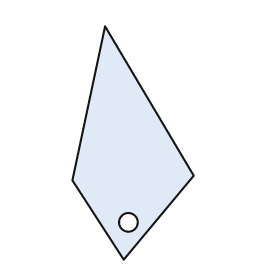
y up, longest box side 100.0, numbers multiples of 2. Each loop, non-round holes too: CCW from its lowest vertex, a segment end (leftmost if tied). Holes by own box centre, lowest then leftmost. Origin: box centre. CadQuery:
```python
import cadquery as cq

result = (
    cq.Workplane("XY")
    .moveTo(-4.0, -50.0)
    .lineTo(26.0, -14.0)
    .lineTo(-12.0, 50.0)
    .lineTo(-26.0, -16.0)
    .close()
    .moveTo(-2.0, -34.0)
    .circle(4.0)
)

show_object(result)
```